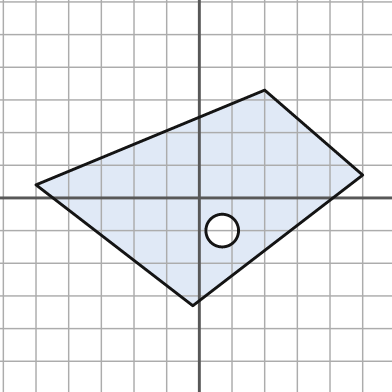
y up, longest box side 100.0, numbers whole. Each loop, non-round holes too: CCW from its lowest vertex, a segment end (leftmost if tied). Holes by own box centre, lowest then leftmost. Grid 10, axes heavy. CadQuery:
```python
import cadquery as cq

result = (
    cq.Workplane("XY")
    .moveTo(-2.0, -33.0)
    .lineTo(50.0, 7.0)
    .lineTo(20.0, 33.0)
    .lineTo(-50.0, 4.0)
    .close()
    .moveTo(7.0, -10.0)
    .circle(5.0)
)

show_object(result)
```